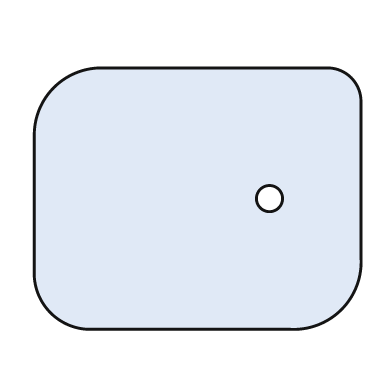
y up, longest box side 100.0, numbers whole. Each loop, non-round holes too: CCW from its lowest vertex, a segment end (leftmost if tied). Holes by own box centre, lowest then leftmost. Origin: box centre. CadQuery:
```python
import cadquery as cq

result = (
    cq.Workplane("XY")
    .moveTo(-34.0, -40.0)
    .lineTo(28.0, -40.0)
    .threePointArc((44.0, -34.0), (50.0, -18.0))
    .lineTo(50.0, 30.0)
    .threePointArc((47.0, 37.0), (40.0, 40.0))
    .lineTo(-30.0, 40.0)
    .threePointArc((-44.0, 34.0), (-50.0, 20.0))
    .lineTo(-50.0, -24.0)
    .threePointArc((-45.0, -35.0), (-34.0, -40.0))
    .close()
    .moveTo(22.0, 0.0)
    .circle(4.0)
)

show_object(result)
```